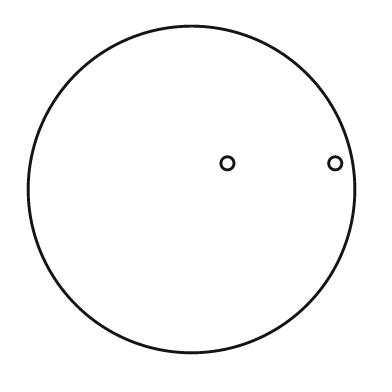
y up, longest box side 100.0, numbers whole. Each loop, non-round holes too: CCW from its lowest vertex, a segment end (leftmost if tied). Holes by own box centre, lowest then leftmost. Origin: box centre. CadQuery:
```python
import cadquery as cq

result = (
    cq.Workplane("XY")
    .moveTo(0.0, 0.0)
    .circle(50.0)
    .moveTo(11.0, 8.0)
    .circle(2.0)
    .moveTo(44.0, 8.0)
    .circle(2.0)
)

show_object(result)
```